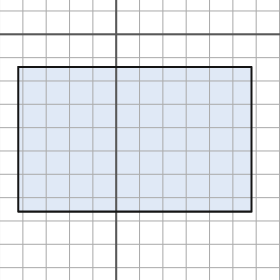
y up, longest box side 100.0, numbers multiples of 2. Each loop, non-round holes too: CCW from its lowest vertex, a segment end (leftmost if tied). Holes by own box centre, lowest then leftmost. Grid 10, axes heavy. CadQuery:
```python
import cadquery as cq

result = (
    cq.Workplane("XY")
    .moveTo(-42.0, -76.0)
    .lineTo(58.0, -76.0)
    .lineTo(58.0, -14.0)
    .lineTo(-42.0, -14.0)
    .close()
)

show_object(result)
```